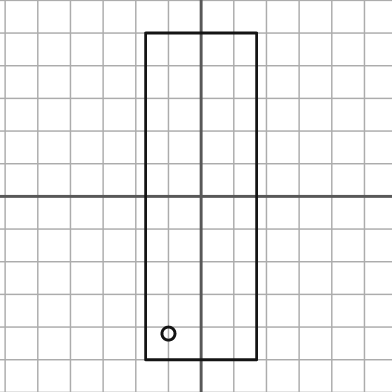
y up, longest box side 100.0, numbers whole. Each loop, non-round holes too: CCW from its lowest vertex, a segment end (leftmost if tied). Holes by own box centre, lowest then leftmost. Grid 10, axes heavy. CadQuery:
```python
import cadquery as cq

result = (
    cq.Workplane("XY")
    .moveTo(-17.0, -50.0)
    .lineTo(17.0, -50.0)
    .lineTo(17.0, 50.0)
    .lineTo(-17.0, 50.0)
    .close()
    .moveTo(-10.0, -42.0)
    .circle(2.0)
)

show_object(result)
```